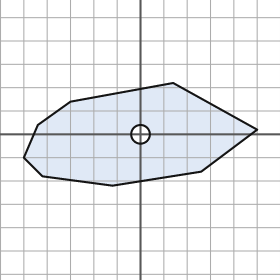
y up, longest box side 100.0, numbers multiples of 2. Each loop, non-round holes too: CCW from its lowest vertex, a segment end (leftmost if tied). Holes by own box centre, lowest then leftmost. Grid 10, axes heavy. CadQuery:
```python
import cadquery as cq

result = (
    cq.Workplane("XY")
    .moveTo(-12.0, -22.0)
    .lineTo(26.0, -16.0)
    .lineTo(50.0, 2.0)
    .lineTo(14.0, 22.0)
    .lineTo(-30.0, 14.0)
    .lineTo(-44.0, 4.0)
    .lineTo(-50.0, -10.0)
    .lineTo(-42.0, -18.0)
    .close()
    .moveTo(0.0, 0.0)
    .circle(4.0)
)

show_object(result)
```